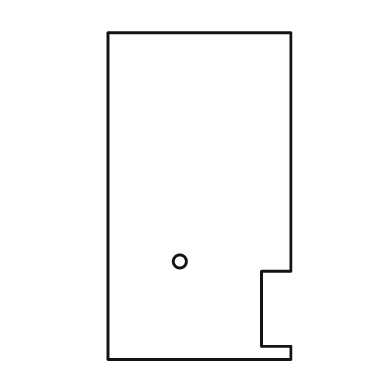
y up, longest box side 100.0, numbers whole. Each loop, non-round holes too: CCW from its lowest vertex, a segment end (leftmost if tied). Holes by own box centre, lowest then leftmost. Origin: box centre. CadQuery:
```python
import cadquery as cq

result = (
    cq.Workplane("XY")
    .moveTo(-28.0, -50.0)
    .lineTo(28.0, -50.0)
    .lineTo(28.0, -46.0)
    .lineTo(19.0, -46.0)
    .lineTo(19.0, -23.0)
    .lineTo(28.0, -23.0)
    .lineTo(28.0, 50.0)
    .lineTo(-28.0, 50.0)
    .close()
    .moveTo(-6.0, -20.0)
    .circle(2.0)
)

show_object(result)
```